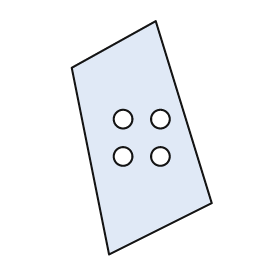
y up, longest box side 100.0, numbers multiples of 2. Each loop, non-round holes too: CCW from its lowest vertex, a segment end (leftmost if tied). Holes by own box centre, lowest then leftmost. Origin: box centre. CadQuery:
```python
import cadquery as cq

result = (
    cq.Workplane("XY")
    .moveTo(-14.0, -50.0)
    .lineTo(30.0, -28.0)
    .lineTo(6.0, 50.0)
    .lineTo(-30.0, 30.0)
    .close()
    .moveTo(-8.0, -8.0)
    .circle(4.0)
    .moveTo(8.0, -8.0)
    .circle(4.0)
    .moveTo(-8.0, 8.0)
    .circle(4.0)
    .moveTo(8.0, 8.0)
    .circle(4.0)
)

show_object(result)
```